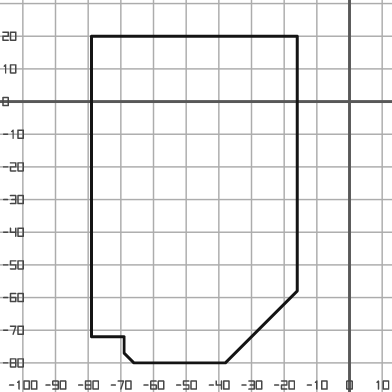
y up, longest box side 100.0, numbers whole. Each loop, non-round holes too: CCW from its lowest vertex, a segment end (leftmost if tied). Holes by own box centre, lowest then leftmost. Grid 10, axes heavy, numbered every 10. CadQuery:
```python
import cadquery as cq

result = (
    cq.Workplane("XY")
    .moveTo(-66.0, -80.0)
    .lineTo(-38.0, -80.0)
    .lineTo(-16.0, -58.0)
    .lineTo(-16.0, 20.0)
    .lineTo(-79.0, 20.0)
    .lineTo(-79.0, -72.0)
    .lineTo(-69.0, -72.0)
    .lineTo(-69.0, -77.0)
    .close()
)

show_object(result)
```